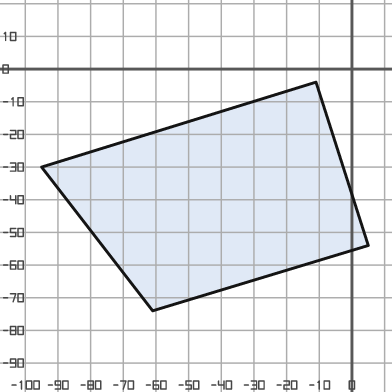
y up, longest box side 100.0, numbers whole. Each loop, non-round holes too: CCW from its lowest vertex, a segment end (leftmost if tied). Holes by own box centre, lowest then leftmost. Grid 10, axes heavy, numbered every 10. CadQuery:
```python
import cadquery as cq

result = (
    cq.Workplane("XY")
    .moveTo(-61.0, -74.0)
    .lineTo(5.0, -54.0)
    .lineTo(-11.0, -4.0)
    .lineTo(-95.0, -30.0)
    .close()
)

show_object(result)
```